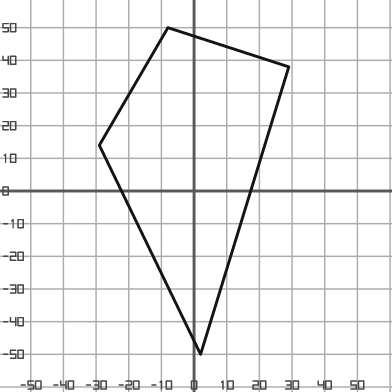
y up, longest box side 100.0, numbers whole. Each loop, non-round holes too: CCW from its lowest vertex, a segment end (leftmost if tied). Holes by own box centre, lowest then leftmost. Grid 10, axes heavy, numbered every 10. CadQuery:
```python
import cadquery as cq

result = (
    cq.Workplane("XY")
    .moveTo(2.0, -50.0)
    .lineTo(29.0, 38.0)
    .lineTo(-8.0, 50.0)
    .lineTo(-29.0, 14.0)
    .close()
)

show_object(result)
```